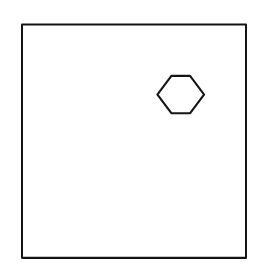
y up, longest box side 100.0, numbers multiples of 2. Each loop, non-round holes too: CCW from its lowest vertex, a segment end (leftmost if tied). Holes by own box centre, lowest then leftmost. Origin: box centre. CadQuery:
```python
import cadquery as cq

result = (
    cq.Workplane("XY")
    .moveTo(-48.0, -50.0)
    .lineTo(48.0, -50.0)
    .lineTo(48.0, 50.0)
    .lineTo(-48.0, 50.0)
    .close()
    .moveTo(16.0, 12.0)
    .lineTo(24.0, 12.0)
    .lineTo(30.0, 20.0)
    .lineTo(24.0, 28.0)
    .lineTo(16.0, 28.0)
    .lineTo(10.0, 20.0)
    .close()
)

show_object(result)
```